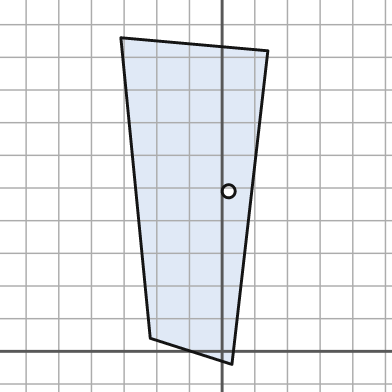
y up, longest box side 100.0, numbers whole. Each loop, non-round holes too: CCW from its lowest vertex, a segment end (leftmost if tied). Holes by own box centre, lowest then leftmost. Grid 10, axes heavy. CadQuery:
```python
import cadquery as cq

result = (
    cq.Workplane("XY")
    .moveTo(3.0, -4.0)
    .lineTo(14.0, 92.0)
    .lineTo(-31.0, 96.0)
    .lineTo(-22.0, 4.0)
    .close()
    .moveTo(2.0, 49.0)
    .circle(2.0)
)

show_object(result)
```